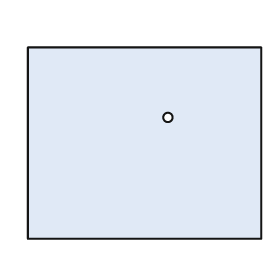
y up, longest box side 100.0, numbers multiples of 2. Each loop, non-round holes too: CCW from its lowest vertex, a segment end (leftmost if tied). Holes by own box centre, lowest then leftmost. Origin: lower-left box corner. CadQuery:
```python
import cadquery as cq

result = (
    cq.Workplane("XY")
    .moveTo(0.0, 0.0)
    .lineTo(100.0, 0.0)
    .lineTo(100.0, 82.0)
    .lineTo(0.0, 82.0)
    .close()
    .moveTo(60.0, 52.0)
    .circle(2.0)
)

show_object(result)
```